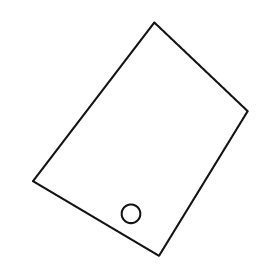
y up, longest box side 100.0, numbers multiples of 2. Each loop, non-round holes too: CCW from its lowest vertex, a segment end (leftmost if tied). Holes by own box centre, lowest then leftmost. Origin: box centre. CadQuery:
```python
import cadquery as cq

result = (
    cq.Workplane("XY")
    .moveTo(8.0, -50.0)
    .lineTo(46.0, 12.0)
    .lineTo(6.0, 50.0)
    .lineTo(-46.0, -18.0)
    .close()
    .moveTo(-4.0, -32.0)
    .circle(4.0)
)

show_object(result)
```